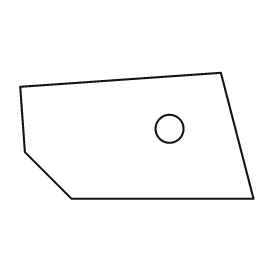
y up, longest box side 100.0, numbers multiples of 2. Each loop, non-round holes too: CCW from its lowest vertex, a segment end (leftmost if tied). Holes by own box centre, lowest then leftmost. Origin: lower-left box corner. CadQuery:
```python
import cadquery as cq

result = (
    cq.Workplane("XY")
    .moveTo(22.0, 0.0)
    .lineTo(100.0, 0.0)
    .lineTo(86.0, 54.0)
    .lineTo(0.0, 48.0)
    .lineTo(2.0, 20.0)
    .close()
    .moveTo(64.0, 30.0)
    .circle(6.0)
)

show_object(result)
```